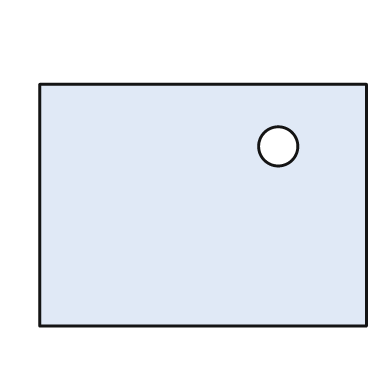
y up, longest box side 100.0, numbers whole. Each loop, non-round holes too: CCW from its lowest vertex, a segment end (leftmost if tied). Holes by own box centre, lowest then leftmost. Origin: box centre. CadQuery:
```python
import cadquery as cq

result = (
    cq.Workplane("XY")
    .moveTo(-50.0, -37.0)
    .lineTo(50.0, -37.0)
    .lineTo(50.0, 37.0)
    .lineTo(-50.0, 37.0)
    .close()
    .moveTo(23.0, 18.0)
    .circle(6.0)
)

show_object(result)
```